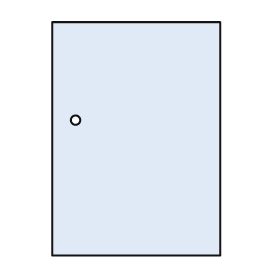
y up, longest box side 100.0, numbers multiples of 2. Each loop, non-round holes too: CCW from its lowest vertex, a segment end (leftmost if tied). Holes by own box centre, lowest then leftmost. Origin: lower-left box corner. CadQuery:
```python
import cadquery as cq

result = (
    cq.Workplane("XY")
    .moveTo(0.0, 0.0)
    .lineTo(72.0, 0.0)
    .lineTo(72.0, 100.0)
    .lineTo(0.0, 100.0)
    .close()
    .moveTo(10.0, 58.0)
    .circle(2.0)
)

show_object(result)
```